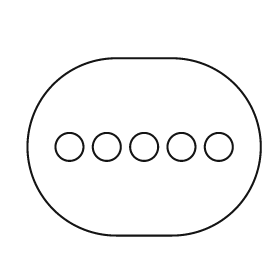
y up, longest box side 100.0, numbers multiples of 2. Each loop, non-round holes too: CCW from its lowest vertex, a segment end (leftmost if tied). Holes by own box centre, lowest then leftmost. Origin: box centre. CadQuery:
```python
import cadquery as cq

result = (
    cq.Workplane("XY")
    .moveTo(-12.0, -38.0)
    .lineTo(12.0, -38.0)
    .threePointArc((50.0, 0.0), (12.0, 38.0))
    .lineTo(-12.0, 38.0)
    .threePointArc((-50.0, 0.0), (-12.0, -38.0))
    .close()
    .moveTo(-32.0, 0.0)
    .circle(6.0)
    .moveTo(-16.0, 0.0)
    .circle(6.0)
    .moveTo(0.0, 0.0)
    .circle(6.0)
    .moveTo(16.0, 0.0)
    .circle(6.0)
    .moveTo(32.0, 0.0)
    .circle(6.0)
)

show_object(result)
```